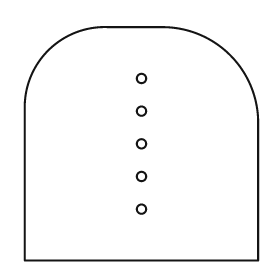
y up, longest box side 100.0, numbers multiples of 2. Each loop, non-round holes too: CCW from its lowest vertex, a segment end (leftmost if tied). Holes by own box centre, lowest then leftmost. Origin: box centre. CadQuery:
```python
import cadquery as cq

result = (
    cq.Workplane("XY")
    .moveTo(-50.0, -50.0)
    .lineTo(50.0, -50.0)
    .lineTo(50.0, 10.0)
    .threePointArc((38.0, 38.0), (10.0, 50.0))
    .lineTo(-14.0, 50.0)
    .threePointArc((-40.0, 40.0), (-50.0, 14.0))
    .close()
    .moveTo(0.0, -28.0)
    .circle(2.0)
    .moveTo(0.0, -14.0)
    .circle(2.0)
    .moveTo(0.0, 0.0)
    .circle(2.0)
    .moveTo(0.0, 14.0)
    .circle(2.0)
    .moveTo(0.0, 28.0)
    .circle(2.0)
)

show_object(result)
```